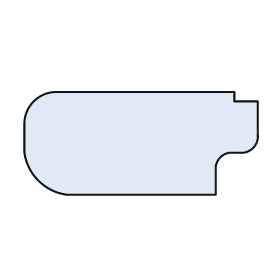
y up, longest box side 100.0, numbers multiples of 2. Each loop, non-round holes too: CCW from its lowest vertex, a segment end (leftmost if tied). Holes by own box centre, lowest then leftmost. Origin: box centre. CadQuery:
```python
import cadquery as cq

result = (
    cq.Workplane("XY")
    .moveTo(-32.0, -22.0)
    .lineTo(32.0, -22.0)
    .lineTo(32.0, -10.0)
    .threePointArc((34.0, -6.0), (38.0, -4.0))
    .lineTo(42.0, -4.0)
    .threePointArc((48.0, -2.0), (50.0, 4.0))
    .lineTo(50.0, 18.0)
    .lineTo(40.0, 18.0)
    .lineTo(40.0, 22.0)
    .lineTo(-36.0, 22.0)
    .threePointArc((-46.0, 18.0), (-50.0, 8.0))
    .lineTo(-50.0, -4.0)
    .threePointArc((-44.0, -16.0), (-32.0, -22.0))
    .close()
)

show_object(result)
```